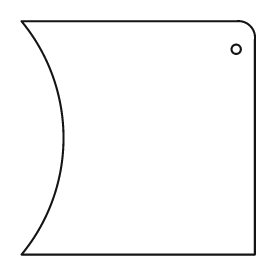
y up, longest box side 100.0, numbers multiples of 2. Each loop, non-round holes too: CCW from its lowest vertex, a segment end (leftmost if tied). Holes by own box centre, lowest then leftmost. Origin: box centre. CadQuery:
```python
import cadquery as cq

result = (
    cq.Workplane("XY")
    .moveTo(-50.0, -50.0)
    .lineTo(50.0, -50.0)
    .lineTo(50.0, 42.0)
    .threePointArc((48.0, 48.0), (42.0, 50.0))
    .lineTo(-50.0, 50.0)
    .threePointArc((-32.0, 0.0), (-50.0, -50.0))
    .close()
    .moveTo(42.0, 38.0)
    .circle(2.0)
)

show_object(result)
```